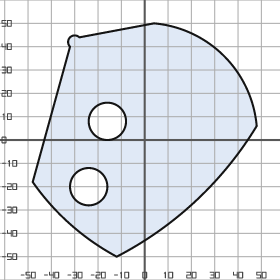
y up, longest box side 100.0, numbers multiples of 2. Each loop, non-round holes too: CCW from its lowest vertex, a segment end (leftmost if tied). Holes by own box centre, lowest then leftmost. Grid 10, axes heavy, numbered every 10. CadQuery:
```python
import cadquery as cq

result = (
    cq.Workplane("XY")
    .moveTo(-12.0, -50.0)
    .threePointArc((22.0, -26.0), (48.0, 6.0))
    .threePointArc((34.0, 36.0), (4.0, 50.0))
    .lineTo(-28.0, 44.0)
    .threePointArc((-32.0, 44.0), (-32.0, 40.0))
    .lineTo(-48.0, -18.0)
    .threePointArc((-32.0, -36.0), (-12.0, -50.0))
    .close()
    .moveTo(-24.0, -20.0)
    .circle(8.0)
    .moveTo(-16.0, 8.0)
    .circle(8.0)
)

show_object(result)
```